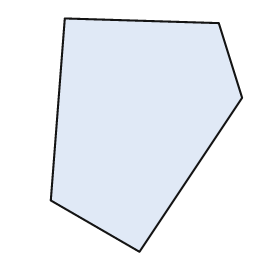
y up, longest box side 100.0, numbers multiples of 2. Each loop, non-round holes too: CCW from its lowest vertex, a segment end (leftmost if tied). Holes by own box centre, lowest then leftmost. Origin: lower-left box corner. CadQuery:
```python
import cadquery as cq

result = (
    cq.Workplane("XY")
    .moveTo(38.0, 0.0)
    .lineTo(82.0, 66.0)
    .lineTo(72.0, 98.0)
    .lineTo(6.0, 100.0)
    .lineTo(0.0, 22.0)
    .close()
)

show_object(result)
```